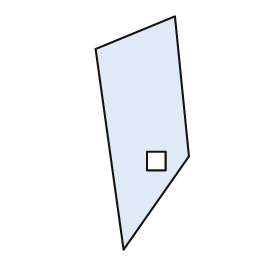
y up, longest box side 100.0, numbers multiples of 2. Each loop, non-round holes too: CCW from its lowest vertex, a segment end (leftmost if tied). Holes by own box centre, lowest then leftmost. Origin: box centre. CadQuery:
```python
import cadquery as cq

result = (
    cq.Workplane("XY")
    .moveTo(-8.0, -50.0)
    .lineTo(20.0, -10.0)
    .lineTo(14.0, 50.0)
    .lineTo(-20.0, 36.0)
    .close()
    .moveTo(2.0, -16.0)
    .lineTo(10.0, -16.0)
    .lineTo(10.0, -8.0)
    .lineTo(2.0, -8.0)
    .close()
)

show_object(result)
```